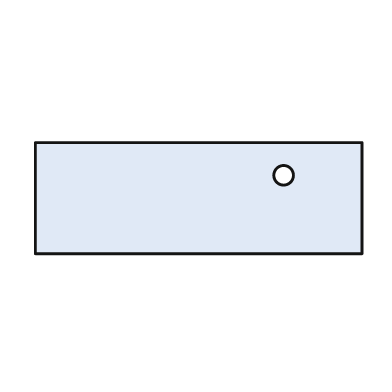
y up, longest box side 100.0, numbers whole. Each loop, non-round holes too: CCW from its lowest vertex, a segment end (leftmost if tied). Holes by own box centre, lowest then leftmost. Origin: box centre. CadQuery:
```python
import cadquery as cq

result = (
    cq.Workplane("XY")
    .moveTo(-50.0, -17.0)
    .lineTo(50.0, -17.0)
    .lineTo(50.0, 17.0)
    .lineTo(-50.0, 17.0)
    .close()
    .moveTo(26.0, 7.0)
    .circle(3.0)
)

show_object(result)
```